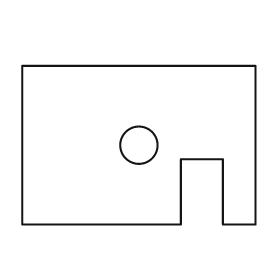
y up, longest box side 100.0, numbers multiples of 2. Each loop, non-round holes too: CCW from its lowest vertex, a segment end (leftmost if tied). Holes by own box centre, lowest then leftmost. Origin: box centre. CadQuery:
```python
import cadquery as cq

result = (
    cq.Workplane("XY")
    .moveTo(-50.0, -34.0)
    .lineTo(18.0, -34.0)
    .lineTo(18.0, -6.0)
    .lineTo(36.0, -6.0)
    .lineTo(36.0, -34.0)
    .lineTo(50.0, -34.0)
    .lineTo(50.0, 34.0)
    .lineTo(-50.0, 34.0)
    .close()
    .moveTo(0.0, 0.0)
    .circle(8.0)
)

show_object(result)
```